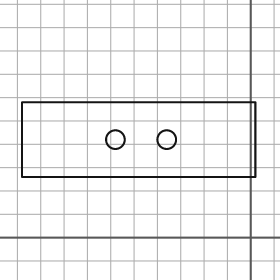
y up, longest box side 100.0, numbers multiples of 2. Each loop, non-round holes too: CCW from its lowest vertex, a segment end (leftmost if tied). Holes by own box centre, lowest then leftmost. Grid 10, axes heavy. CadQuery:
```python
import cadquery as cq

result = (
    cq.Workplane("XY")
    .moveTo(-98.0, 26.0)
    .lineTo(2.0, 26.0)
    .lineTo(2.0, 58.0)
    .lineTo(-98.0, 58.0)
    .close()
    .moveTo(-58.0, 42.0)
    .circle(4.0)
    .moveTo(-36.0, 42.0)
    .circle(4.0)
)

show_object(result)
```